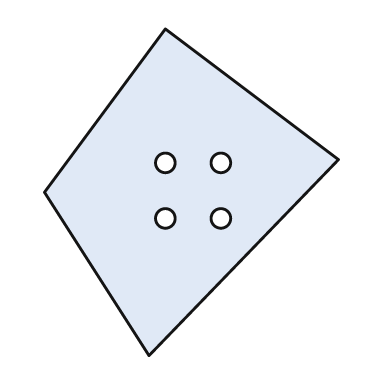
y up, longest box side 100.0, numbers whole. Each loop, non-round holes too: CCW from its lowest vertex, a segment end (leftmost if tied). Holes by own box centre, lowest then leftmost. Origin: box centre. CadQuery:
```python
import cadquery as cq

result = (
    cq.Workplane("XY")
    .moveTo(-13.0, -50.0)
    .lineTo(45.0, 10.0)
    .lineTo(-8.0, 50.0)
    .lineTo(-45.0, 0.0)
    .close()
    .moveTo(-8.0, -8.0)
    .circle(3.0)
    .moveTo(9.0, -8.0)
    .circle(3.0)
    .moveTo(-8.0, 9.0)
    .circle(3.0)
    .moveTo(9.0, 9.0)
    .circle(3.0)
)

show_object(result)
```